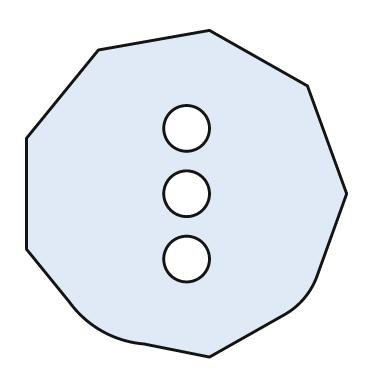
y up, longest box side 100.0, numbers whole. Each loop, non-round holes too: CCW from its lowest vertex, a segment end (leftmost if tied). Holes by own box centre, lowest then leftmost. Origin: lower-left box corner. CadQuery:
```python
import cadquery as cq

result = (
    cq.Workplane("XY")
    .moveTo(56.0, 0.0)
    .lineTo(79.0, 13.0)
    .threePointArc((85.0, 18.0), (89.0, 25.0))
    .lineTo(98.0, 50.0)
    .lineTo(86.0, 83.0)
    .lineTo(56.0, 100.0)
    .lineTo(22.0, 94.0)
    .lineTo(0.0, 67.0)
    .lineTo(0.0, 33.0)
    .lineTo(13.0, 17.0)
    .threePointArc((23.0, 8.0), (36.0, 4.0))
    .close()
    .moveTo(49.0, 30.0)
    .circle(7.0)
    .moveTo(49.0, 50.0)
    .circle(7.0)
    .moveTo(49.0, 70.0)
    .circle(7.0)
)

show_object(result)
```